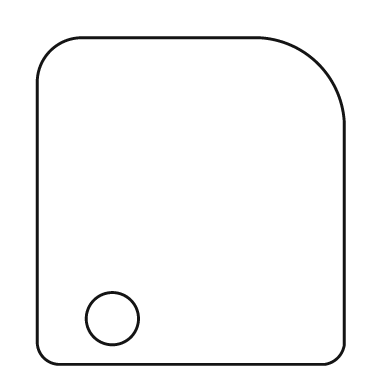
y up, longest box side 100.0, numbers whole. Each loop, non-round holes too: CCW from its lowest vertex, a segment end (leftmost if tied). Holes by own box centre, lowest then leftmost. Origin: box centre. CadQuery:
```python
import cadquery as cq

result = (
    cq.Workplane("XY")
    .moveTo(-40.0, -50.0)
    .lineTo(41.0, -50.0)
    .threePointArc((45.0, -48.0), (47.0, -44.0))
    .lineTo(47.0, 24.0)
    .threePointArc((39.0, 42.0), (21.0, 50.0))
    .lineTo(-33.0, 50.0)
    .threePointArc((-43.0, 46.0), (-47.0, 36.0))
    .lineTo(-47.0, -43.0)
    .threePointArc((-45.0, -48.0), (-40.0, -50.0))
    .close()
    .moveTo(-24.0, -36.0)
    .circle(8.0)
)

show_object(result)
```